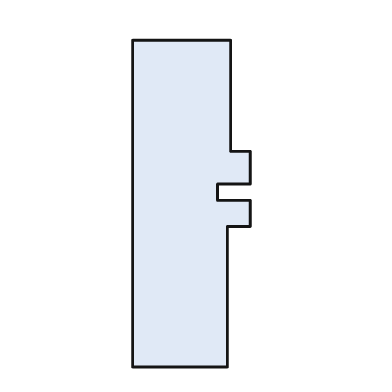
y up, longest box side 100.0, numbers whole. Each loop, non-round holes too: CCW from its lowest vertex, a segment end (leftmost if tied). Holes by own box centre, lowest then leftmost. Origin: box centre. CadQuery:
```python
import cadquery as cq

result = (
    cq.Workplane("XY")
    .moveTo(-18.0, -50.0)
    .lineTo(11.0, -50.0)
    .lineTo(11.0, -7.0)
    .lineTo(18.0, -7.0)
    .lineTo(18.0, 1.0)
    .lineTo(8.0, 1.0)
    .lineTo(8.0, 6.0)
    .lineTo(18.0, 6.0)
    .lineTo(18.0, 16.0)
    .lineTo(12.0, 16.0)
    .lineTo(12.0, 50.0)
    .lineTo(-18.0, 50.0)
    .close()
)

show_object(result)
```